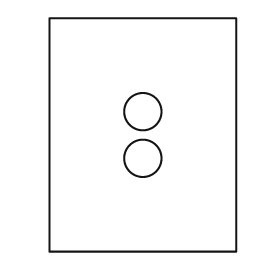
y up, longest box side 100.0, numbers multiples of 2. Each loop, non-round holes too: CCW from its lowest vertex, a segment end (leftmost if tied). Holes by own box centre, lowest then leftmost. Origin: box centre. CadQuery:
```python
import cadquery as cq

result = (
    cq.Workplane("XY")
    .moveTo(-40.0, -50.0)
    .lineTo(40.0, -50.0)
    .lineTo(40.0, 50.0)
    .lineTo(-40.0, 50.0)
    .close()
    .moveTo(0.0, -10.0)
    .circle(8.0)
    .moveTo(0.0, 10.0)
    .circle(8.0)
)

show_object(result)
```